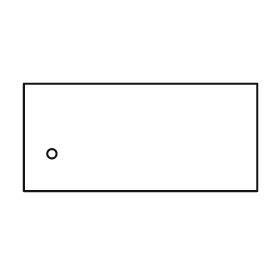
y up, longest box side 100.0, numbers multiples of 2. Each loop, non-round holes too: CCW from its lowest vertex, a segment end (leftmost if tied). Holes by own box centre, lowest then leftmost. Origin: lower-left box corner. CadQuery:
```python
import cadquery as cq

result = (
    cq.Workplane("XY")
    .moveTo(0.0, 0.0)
    .lineTo(100.0, 0.0)
    .lineTo(100.0, 46.0)
    .lineTo(0.0, 46.0)
    .close()
    .moveTo(12.0, 16.0)
    .circle(2.0)
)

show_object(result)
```